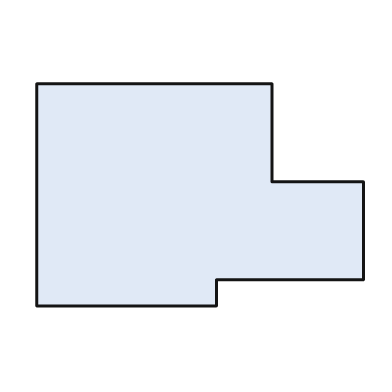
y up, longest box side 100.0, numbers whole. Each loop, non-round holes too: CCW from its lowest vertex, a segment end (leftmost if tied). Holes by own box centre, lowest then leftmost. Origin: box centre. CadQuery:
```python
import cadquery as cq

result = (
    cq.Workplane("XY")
    .moveTo(-50.0, -34.0)
    .lineTo(5.0, -34.0)
    .lineTo(5.0, -26.0)
    .lineTo(50.0, -26.0)
    .lineTo(50.0, 4.0)
    .lineTo(22.0, 4.0)
    .lineTo(22.0, 34.0)
    .lineTo(-50.0, 34.0)
    .close()
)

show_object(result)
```